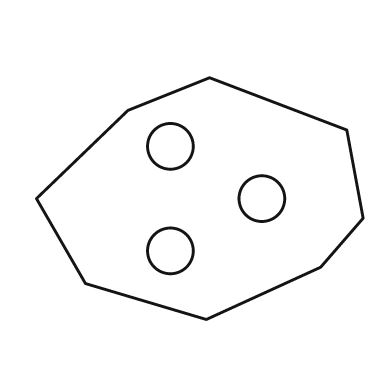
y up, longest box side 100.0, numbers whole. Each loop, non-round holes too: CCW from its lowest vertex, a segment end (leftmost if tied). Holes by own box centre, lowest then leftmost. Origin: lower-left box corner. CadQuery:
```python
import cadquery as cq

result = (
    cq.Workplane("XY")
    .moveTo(52.0, 0.0)
    .lineTo(87.0, 16.0)
    .lineTo(100.0, 31.0)
    .lineTo(95.0, 58.0)
    .lineTo(53.0, 74.0)
    .lineTo(28.0, 64.0)
    .lineTo(0.0, 37.0)
    .lineTo(15.0, 11.0)
    .close()
    .moveTo(41.0, 21.0)
    .circle(7.0)
    .moveTo(69.0, 37.0)
    .circle(7.0)
    .moveTo(41.0, 53.0)
    .circle(7.0)
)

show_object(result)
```